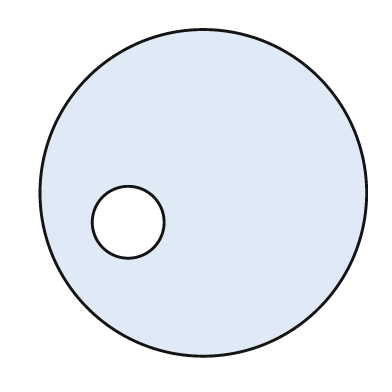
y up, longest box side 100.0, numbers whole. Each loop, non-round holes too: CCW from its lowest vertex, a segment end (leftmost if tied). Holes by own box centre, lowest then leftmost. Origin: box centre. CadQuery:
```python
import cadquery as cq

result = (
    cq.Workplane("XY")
    .moveTo(0.0, 0.0)
    .circle(50.0)
    .moveTo(-23.0, -9.0)
    .circle(11.0)
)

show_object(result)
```